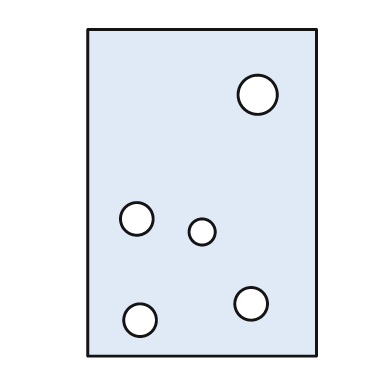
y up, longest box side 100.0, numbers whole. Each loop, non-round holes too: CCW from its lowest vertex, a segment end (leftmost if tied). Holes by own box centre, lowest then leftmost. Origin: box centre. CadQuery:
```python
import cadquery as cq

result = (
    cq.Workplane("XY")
    .moveTo(-35.0, -50.0)
    .lineTo(35.0, -50.0)
    .lineTo(35.0, 50.0)
    .lineTo(-35.0, 50.0)
    .close()
    .moveTo(-19.0, -39.0)
    .circle(5.0)
    .moveTo(15.0, -34.0)
    .circle(5.0)
    .moveTo(0.0, -12.0)
    .circle(4.0)
    .moveTo(-20.0, -8.0)
    .circle(5.0)
    .moveTo(17.0, 30.0)
    .circle(6.0)
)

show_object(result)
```